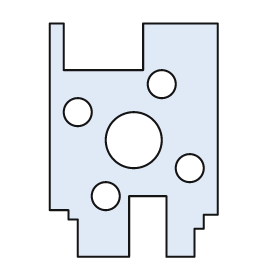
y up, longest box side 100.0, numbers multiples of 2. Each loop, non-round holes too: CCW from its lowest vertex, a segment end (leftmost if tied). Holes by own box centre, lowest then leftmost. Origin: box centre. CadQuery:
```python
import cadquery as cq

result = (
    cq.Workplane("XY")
    .moveTo(-24.0, -50.0)
    .lineTo(-2.0, -50.0)
    .lineTo(-2.0, -24.0)
    .lineTo(14.0, -24.0)
    .lineTo(14.0, -50.0)
    .lineTo(26.0, -50.0)
    .lineTo(26.0, -38.0)
    .lineTo(30.0, -38.0)
    .lineTo(30.0, -32.0)
    .lineTo(36.0, -32.0)
    .lineTo(36.0, 50.0)
    .lineTo(4.0, 50.0)
    .lineTo(4.0, 30.0)
    .lineTo(-30.0, 30.0)
    .lineTo(-30.0, 50.0)
    .lineTo(-36.0, 50.0)
    .lineTo(-36.0, -30.0)
    .lineTo(-28.0, -30.0)
    .lineTo(-28.0, -34.0)
    .lineTo(-24.0, -34.0)
    .close()
    .moveTo(-12.0, -24.0)
    .circle(6.0)
    .moveTo(24.0, -12.0)
    .circle(6.0)
    .moveTo(0.0, 0.0)
    .circle(12.0)
    .moveTo(-24.0, 12.0)
    .circle(6.0)
    .moveTo(12.0, 24.0)
    .circle(6.0)
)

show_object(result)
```